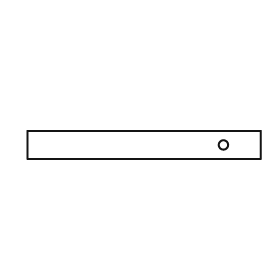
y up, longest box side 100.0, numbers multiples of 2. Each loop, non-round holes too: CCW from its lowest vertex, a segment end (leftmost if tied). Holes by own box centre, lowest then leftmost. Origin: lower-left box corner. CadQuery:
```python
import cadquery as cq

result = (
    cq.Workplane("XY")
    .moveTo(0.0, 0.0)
    .lineTo(100.0, 0.0)
    .lineTo(100.0, 12.0)
    .lineTo(0.0, 12.0)
    .close()
    .moveTo(84.0, 6.0)
    .circle(2.0)
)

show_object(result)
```